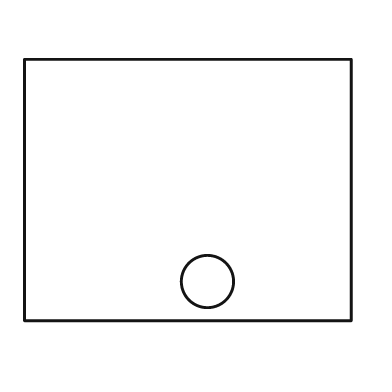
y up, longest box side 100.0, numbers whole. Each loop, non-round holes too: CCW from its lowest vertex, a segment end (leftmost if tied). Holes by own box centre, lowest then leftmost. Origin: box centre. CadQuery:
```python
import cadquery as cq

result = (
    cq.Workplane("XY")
    .moveTo(-50.0, -40.0)
    .lineTo(50.0, -40.0)
    .lineTo(50.0, 40.0)
    .lineTo(-50.0, 40.0)
    .close()
    .moveTo(6.0, -28.0)
    .circle(8.0)
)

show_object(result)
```